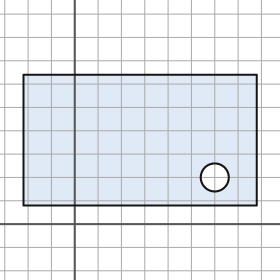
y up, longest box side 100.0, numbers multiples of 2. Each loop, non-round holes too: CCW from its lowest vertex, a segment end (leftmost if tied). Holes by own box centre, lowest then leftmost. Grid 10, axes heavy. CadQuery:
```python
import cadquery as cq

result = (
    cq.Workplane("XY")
    .moveTo(-22.0, 8.0)
    .lineTo(78.0, 8.0)
    .lineTo(78.0, 64.0)
    .lineTo(-22.0, 64.0)
    .close()
    .moveTo(60.0, 20.0)
    .circle(6.0)
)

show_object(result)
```